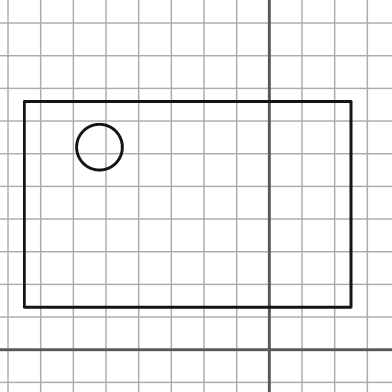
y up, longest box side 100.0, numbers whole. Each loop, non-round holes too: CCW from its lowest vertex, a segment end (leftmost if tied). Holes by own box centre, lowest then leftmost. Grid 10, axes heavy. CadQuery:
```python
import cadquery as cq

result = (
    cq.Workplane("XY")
    .moveTo(-75.0, 13.0)
    .lineTo(25.0, 13.0)
    .lineTo(25.0, 76.0)
    .lineTo(-75.0, 76.0)
    .close()
    .moveTo(-52.0, 62.0)
    .circle(7.0)
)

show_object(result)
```